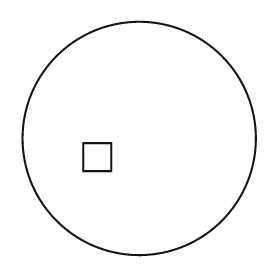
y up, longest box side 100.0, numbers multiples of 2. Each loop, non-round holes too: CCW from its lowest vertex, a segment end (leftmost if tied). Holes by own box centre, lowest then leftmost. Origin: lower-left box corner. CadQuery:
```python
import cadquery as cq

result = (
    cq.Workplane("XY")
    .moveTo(50.0, 50.0)
    .circle(50.0)
    .moveTo(26.0, 36.0)
    .lineTo(38.0, 36.0)
    .lineTo(38.0, 48.0)
    .lineTo(26.0, 48.0)
    .close()
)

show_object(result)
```